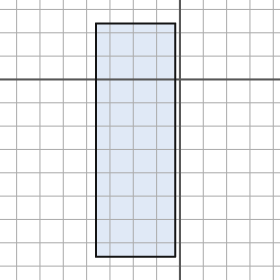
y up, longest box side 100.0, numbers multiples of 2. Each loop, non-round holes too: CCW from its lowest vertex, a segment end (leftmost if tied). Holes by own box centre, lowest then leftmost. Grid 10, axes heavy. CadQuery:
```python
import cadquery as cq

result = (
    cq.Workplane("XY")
    .moveTo(-36.0, -76.0)
    .lineTo(-2.0, -76.0)
    .lineTo(-2.0, 24.0)
    .lineTo(-36.0, 24.0)
    .close()
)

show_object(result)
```